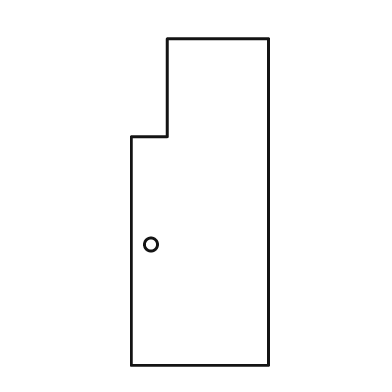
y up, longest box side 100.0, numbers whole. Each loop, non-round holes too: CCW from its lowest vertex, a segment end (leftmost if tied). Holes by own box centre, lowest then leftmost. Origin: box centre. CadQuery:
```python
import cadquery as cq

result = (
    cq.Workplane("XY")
    .moveTo(-21.0, -50.0)
    .lineTo(21.0, -50.0)
    .lineTo(21.0, 50.0)
    .lineTo(-10.0, 50.0)
    .lineTo(-10.0, 20.0)
    .lineTo(-21.0, 20.0)
    .close()
    .moveTo(-15.0, -13.0)
    .circle(2.0)
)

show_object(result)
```